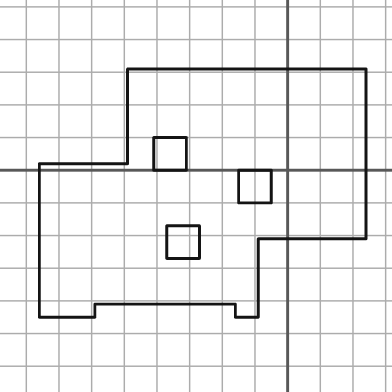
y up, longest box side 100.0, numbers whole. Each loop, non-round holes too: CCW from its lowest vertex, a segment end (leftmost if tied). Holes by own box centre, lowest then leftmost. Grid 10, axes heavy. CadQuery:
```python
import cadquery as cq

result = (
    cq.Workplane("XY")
    .moveTo(-76.0, -45.0)
    .lineTo(-59.0, -45.0)
    .lineTo(-59.0, -41.0)
    .lineTo(-16.0, -41.0)
    .lineTo(-16.0, -45.0)
    .lineTo(-9.0, -45.0)
    .lineTo(-9.0, -21.0)
    .lineTo(24.0, -21.0)
    .lineTo(24.0, 31.0)
    .lineTo(-49.0, 31.0)
    .lineTo(-49.0, 2.0)
    .lineTo(-76.0, 2.0)
    .close()
    .moveTo(-37.0, -27.0)
    .lineTo(-27.0, -27.0)
    .lineTo(-27.0, -17.0)
    .lineTo(-37.0, -17.0)
    .close()
    .moveTo(-15.0, -10.0)
    .lineTo(-5.0, -10.0)
    .lineTo(-5.0, 0.0)
    .lineTo(-15.0, 0.0)
    .close()
    .moveTo(-41.0, 0.0)
    .lineTo(-31.0, 0.0)
    .lineTo(-31.0, 10.0)
    .lineTo(-41.0, 10.0)
    .close()
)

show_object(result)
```